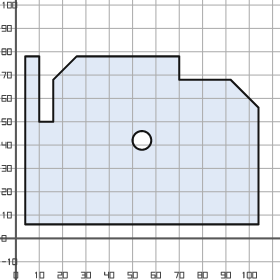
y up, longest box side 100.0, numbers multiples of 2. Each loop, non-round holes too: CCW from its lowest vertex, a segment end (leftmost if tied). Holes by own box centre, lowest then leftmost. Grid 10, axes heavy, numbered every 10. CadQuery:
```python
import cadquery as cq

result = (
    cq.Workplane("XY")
    .moveTo(4.0, 6.0)
    .lineTo(104.0, 6.0)
    .lineTo(104.0, 56.0)
    .lineTo(92.0, 68.0)
    .lineTo(70.0, 68.0)
    .lineTo(70.0, 78.0)
    .lineTo(26.0, 78.0)
    .lineTo(16.0, 68.0)
    .lineTo(16.0, 50.0)
    .lineTo(10.0, 50.0)
    .lineTo(10.0, 78.0)
    .lineTo(4.0, 78.0)
    .close()
    .moveTo(54.0, 42.0)
    .circle(4.0)
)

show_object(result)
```